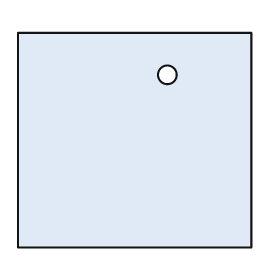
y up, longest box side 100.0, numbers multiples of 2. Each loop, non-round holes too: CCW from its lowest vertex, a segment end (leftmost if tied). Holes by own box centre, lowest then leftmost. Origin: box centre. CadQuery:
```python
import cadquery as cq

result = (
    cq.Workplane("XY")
    .moveTo(-50.0, -46.0)
    .lineTo(50.0, -46.0)
    .lineTo(50.0, 46.0)
    .lineTo(-50.0, 46.0)
    .close()
    .moveTo(14.0, 28.0)
    .circle(4.0)
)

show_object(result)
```